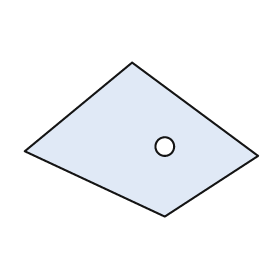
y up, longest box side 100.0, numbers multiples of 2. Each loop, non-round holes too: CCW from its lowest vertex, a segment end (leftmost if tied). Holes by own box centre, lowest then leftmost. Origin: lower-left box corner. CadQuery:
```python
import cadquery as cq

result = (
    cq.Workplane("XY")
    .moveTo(60.0, 0.0)
    .lineTo(100.0, 26.0)
    .lineTo(46.0, 66.0)
    .lineTo(0.0, 28.0)
    .close()
    .moveTo(60.0, 30.0)
    .circle(4.0)
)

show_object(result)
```